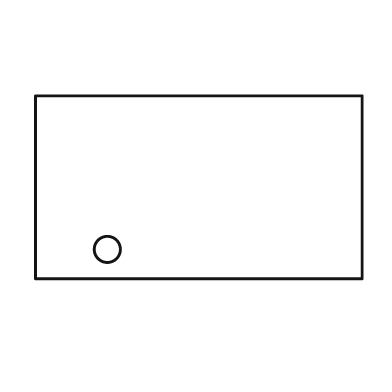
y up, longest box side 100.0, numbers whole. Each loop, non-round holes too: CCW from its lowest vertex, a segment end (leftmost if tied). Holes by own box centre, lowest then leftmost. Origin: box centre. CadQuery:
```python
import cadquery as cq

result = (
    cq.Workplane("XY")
    .moveTo(-50.0, -28.0)
    .lineTo(50.0, -28.0)
    .lineTo(50.0, 28.0)
    .lineTo(-50.0, 28.0)
    .close()
    .moveTo(-28.0, -19.0)
    .circle(4.0)
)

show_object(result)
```